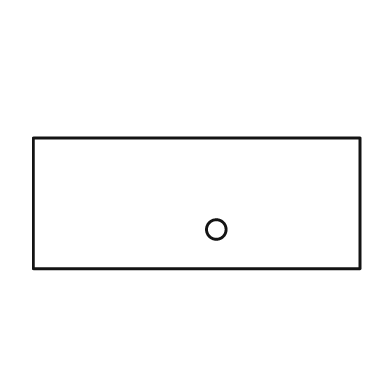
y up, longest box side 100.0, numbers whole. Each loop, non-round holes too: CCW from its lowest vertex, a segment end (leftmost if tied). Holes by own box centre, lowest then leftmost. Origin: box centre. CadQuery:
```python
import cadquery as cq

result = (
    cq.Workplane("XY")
    .moveTo(-50.0, -20.0)
    .lineTo(50.0, -20.0)
    .lineTo(50.0, 20.0)
    .lineTo(-50.0, 20.0)
    .close()
    .moveTo(6.0, -8.0)
    .circle(3.0)
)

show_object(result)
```